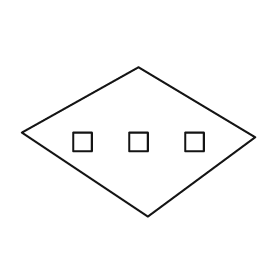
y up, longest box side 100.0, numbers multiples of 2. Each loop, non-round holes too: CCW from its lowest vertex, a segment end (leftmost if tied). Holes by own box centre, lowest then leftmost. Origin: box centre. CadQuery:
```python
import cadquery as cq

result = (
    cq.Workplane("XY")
    .moveTo(4.0, -32.0)
    .lineTo(50.0, 2.0)
    .lineTo(0.0, 32.0)
    .lineTo(-50.0, 4.0)
    .close()
    .moveTo(-28.0, -4.0)
    .lineTo(-20.0, -4.0)
    .lineTo(-20.0, 4.0)
    .lineTo(-28.0, 4.0)
    .close()
    .moveTo(-4.0, -4.0)
    .lineTo(4.0, -4.0)
    .lineTo(4.0, 4.0)
    .lineTo(-4.0, 4.0)
    .close()
    .moveTo(20.0, -4.0)
    .lineTo(28.0, -4.0)
    .lineTo(28.0, 4.0)
    .lineTo(20.0, 4.0)
    .close()
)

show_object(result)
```